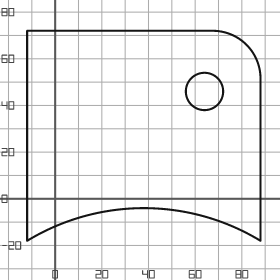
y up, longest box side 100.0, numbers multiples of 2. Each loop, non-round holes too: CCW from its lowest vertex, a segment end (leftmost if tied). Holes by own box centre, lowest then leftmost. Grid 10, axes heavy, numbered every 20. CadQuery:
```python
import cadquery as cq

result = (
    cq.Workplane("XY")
    .moveTo(-12.0, -18.0)
    .threePointArc((38.0, -4.0), (88.0, -18.0))
    .lineTo(88.0, 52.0)
    .threePointArc((82.0, 66.0), (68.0, 72.0))
    .lineTo(-12.0, 72.0)
    .close()
    .moveTo(64.0, 46.0)
    .circle(8.0)
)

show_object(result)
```